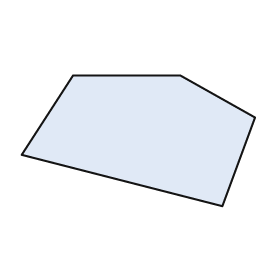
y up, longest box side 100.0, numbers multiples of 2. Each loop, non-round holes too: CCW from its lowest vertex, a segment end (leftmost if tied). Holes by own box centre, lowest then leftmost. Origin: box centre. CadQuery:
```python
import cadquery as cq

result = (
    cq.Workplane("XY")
    .moveTo(36.0, -28.0)
    .lineTo(50.0, 10.0)
    .lineTo(18.0, 28.0)
    .lineTo(-28.0, 28.0)
    .lineTo(-50.0, -6.0)
    .close()
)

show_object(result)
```